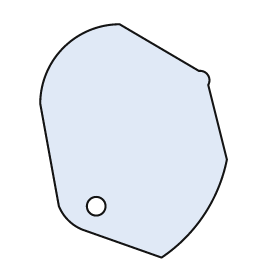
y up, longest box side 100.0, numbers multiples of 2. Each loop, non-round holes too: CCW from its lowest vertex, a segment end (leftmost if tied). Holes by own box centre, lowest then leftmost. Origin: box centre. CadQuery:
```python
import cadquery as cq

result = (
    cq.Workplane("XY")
    .moveTo(12.0, -50.0)
    .threePointArc((30.0, -32.0), (40.0, -8.0))
    .lineTo(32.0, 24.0)
    .threePointArc((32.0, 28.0), (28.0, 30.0))
    .lineTo(-6.0, 50.0)
    .threePointArc((-30.0, 40.0), (-40.0, 16.0))
    .lineTo(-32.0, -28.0)
    .threePointArc((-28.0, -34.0), (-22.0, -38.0))
    .close()
    .moveTo(-16.0, -28.0)
    .circle(4.0)
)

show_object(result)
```